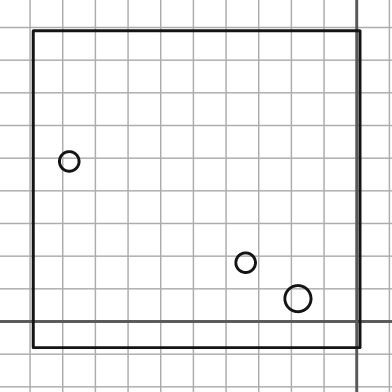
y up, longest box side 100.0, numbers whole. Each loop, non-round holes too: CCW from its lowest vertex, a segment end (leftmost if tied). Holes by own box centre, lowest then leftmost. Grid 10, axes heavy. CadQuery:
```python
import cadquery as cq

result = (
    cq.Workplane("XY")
    .moveTo(-99.0, -8.0)
    .lineTo(1.0, -8.0)
    .lineTo(1.0, 89.0)
    .lineTo(-99.0, 89.0)
    .close()
    .moveTo(-18.0, 7.0)
    .circle(4.0)
    .moveTo(-34.0, 18.0)
    .circle(3.0)
    .moveTo(-88.0, 49.0)
    .circle(3.0)
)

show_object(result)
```